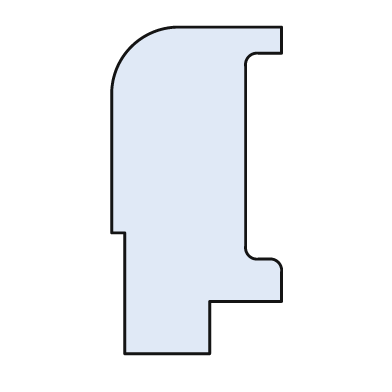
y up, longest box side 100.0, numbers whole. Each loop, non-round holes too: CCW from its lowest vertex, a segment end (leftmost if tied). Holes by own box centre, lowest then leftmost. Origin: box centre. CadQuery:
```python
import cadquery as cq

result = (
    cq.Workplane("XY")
    .moveTo(-22.0, -50.0)
    .lineTo(4.0, -50.0)
    .lineTo(4.0, -34.0)
    .lineTo(26.0, -34.0)
    .lineTo(26.0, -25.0)
    .threePointArc((25.0, -22.0), (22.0, -21.0))
    .lineTo(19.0, -21.0)
    .threePointArc((16.0, -20.0), (15.0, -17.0))
    .lineTo(15.0, 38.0)
    .threePointArc((16.0, 41.0), (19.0, 42.0))
    .lineTo(26.0, 42.0)
    .lineTo(26.0, 50.0)
    .lineTo(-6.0, 50.0)
    .threePointArc((-20.0, 44.0), (-26.0, 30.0))
    .lineTo(-26.0, -13.0)
    .lineTo(-22.0, -13.0)
    .close()
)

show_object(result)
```